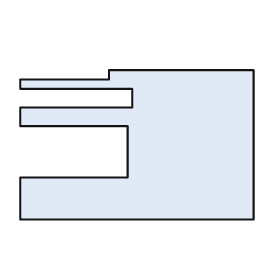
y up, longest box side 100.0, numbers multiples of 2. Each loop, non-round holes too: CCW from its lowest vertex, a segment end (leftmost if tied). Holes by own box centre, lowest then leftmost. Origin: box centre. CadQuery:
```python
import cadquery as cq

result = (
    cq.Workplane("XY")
    .moveTo(-50.0, -32.0)
    .lineTo(50.0, -32.0)
    .lineTo(50.0, 32.0)
    .lineTo(-12.0, 32.0)
    .lineTo(-12.0, 28.0)
    .lineTo(-50.0, 28.0)
    .lineTo(-50.0, 24.0)
    .lineTo(-2.0, 24.0)
    .lineTo(-2.0, 16.0)
    .lineTo(-50.0, 16.0)
    .lineTo(-50.0, 8.0)
    .lineTo(-4.0, 8.0)
    .lineTo(-4.0, -14.0)
    .lineTo(-50.0, -14.0)
    .close()
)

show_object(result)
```